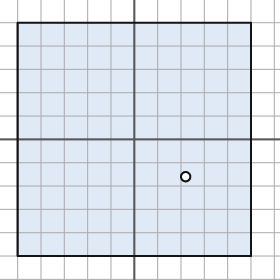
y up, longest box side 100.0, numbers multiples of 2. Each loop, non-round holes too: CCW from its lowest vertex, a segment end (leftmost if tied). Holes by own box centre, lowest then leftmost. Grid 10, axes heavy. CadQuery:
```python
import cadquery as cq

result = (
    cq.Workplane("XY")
    .moveTo(-50.0, -50.0)
    .lineTo(50.0, -50.0)
    .lineTo(50.0, 50.0)
    .lineTo(-50.0, 50.0)
    .close()
    .moveTo(22.0, -16.0)
    .circle(2.0)
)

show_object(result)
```